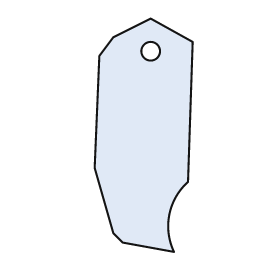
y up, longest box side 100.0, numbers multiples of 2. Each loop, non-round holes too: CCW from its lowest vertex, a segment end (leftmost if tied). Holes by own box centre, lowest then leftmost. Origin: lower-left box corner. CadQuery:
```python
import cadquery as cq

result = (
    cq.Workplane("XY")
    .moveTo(34.0, 0.0)
    .threePointArc((32.0, 16.0), (40.0, 30.0))
    .lineTo(42.0, 90.0)
    .lineTo(24.0, 100.0)
    .lineTo(8.0, 92.0)
    .lineTo(2.0, 84.0)
    .lineTo(0.0, 36.0)
    .lineTo(8.0, 8.0)
    .lineTo(12.0, 4.0)
    .close()
    .moveTo(24.0, 86.0)
    .circle(4.0)
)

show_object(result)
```